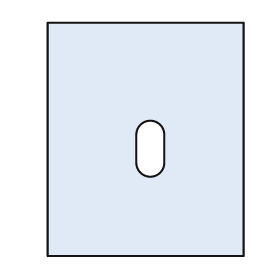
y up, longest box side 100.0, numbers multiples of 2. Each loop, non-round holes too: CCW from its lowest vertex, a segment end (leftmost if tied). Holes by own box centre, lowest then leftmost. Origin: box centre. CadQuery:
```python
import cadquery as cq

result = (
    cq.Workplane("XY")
    .moveTo(-42.0, -50.0)
    .lineTo(42.0, -50.0)
    .lineTo(42.0, 50.0)
    .lineTo(-42.0, 50.0)
    .close()
    .moveTo(-4.0, -10.0)
    .threePointArc((2.0, -16.0), (8.0, -10.0))
    .lineTo(8.0, 2.0)
    .threePointArc((2.0, 8.0), (-4.0, 2.0))
    .close()
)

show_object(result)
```